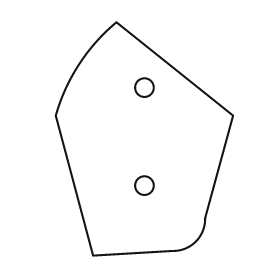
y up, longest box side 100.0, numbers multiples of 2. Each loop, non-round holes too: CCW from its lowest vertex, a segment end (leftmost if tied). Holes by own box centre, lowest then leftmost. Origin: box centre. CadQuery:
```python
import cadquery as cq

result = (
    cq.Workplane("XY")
    .moveTo(-22.0, -50.0)
    .lineTo(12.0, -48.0)
    .threePointArc((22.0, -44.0), (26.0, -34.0))
    .lineTo(38.0, 10.0)
    .lineTo(-12.0, 50.0)
    .threePointArc((-28.0, 32.0), (-38.0, 10.0))
    .close()
    .moveTo(0.0, -20.0)
    .circle(4.0)
    .moveTo(0.0, 22.0)
    .circle(4.0)
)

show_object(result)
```